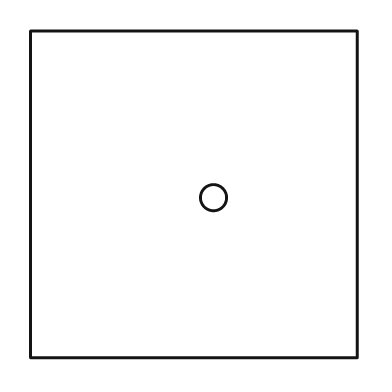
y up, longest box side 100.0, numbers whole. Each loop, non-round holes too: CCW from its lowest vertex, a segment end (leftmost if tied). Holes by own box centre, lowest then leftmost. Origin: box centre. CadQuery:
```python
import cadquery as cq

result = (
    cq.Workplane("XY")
    .moveTo(-50.0, -50.0)
    .lineTo(50.0, -50.0)
    .lineTo(50.0, 50.0)
    .lineTo(-50.0, 50.0)
    .close()
    .moveTo(6.0, -1.0)
    .circle(4.0)
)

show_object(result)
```